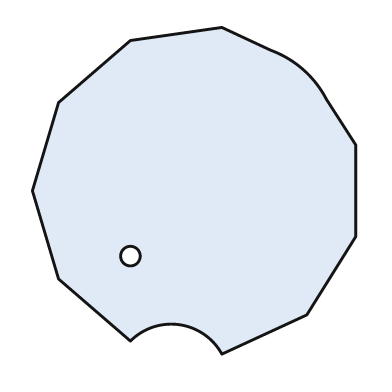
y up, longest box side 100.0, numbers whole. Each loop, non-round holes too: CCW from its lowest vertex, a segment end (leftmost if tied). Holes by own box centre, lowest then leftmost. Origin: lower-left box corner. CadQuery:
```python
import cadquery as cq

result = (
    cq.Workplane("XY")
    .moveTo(58.0, 0.0)
    .lineTo(84.0, 12.0)
    .lineTo(99.0, 36.0)
    .lineTo(99.0, 64.0)
    .lineTo(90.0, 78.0)
    .threePointArc((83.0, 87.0), (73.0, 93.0))
    .lineTo(58.0, 100.0)
    .lineTo(30.0, 96.0)
    .lineTo(8.0, 77.0)
    .lineTo(0.0, 50.0)
    .lineTo(8.0, 23.0)
    .lineTo(30.0, 4.0)
    .threePointArc((45.0, 9.0), (58.0, 0.0))
    .close()
    .moveTo(30.0, 30.0)
    .circle(3.0)
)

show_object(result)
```